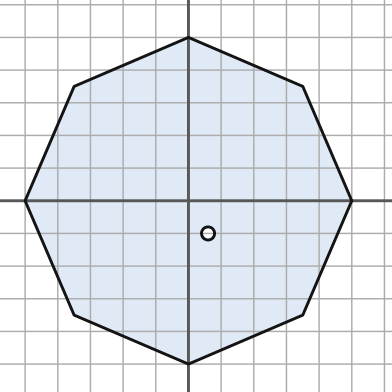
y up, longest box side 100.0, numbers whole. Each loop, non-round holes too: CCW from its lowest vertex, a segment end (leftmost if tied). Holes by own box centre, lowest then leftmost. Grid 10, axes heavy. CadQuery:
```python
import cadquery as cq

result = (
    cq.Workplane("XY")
    .moveTo(0.0, -50.0)
    .lineTo(35.0, -35.0)
    .lineTo(50.0, 0.0)
    .lineTo(35.0, 35.0)
    .lineTo(0.0, 50.0)
    .lineTo(-35.0, 35.0)
    .lineTo(-50.0, 0.0)
    .lineTo(-35.0, -35.0)
    .close()
    .moveTo(6.0, -10.0)
    .circle(2.0)
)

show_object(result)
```